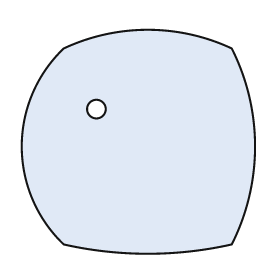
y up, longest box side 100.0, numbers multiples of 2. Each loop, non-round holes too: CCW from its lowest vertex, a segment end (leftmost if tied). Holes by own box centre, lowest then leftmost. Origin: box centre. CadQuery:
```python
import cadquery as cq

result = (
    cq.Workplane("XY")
    .moveTo(-32.0, -44.0)
    .threePointArc((4.0, -48.0), (40.0, -44.0))
    .threePointArc((50.0, -2.0), (40.0, 40.0))
    .threePointArc((4.0, 48.0), (-32.0, 40.0))
    .threePointArc((-50.0, -2.0), (-32.0, -44.0))
    .close()
    .moveTo(-18.0, 14.0)
    .circle(4.0)
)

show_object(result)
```